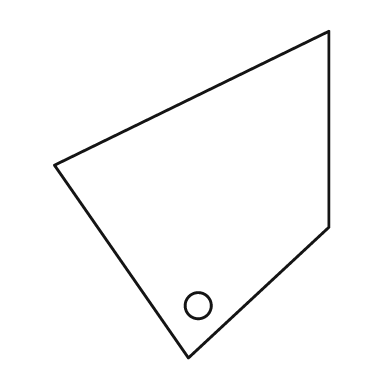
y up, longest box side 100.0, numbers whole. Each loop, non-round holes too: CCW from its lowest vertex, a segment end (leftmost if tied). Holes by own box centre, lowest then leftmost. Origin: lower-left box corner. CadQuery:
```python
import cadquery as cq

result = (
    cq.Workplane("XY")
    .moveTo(41.0, 0.0)
    .lineTo(84.0, 40.0)
    .lineTo(84.0, 100.0)
    .lineTo(0.0, 59.0)
    .close()
    .moveTo(44.0, 16.0)
    .circle(4.0)
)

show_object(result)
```